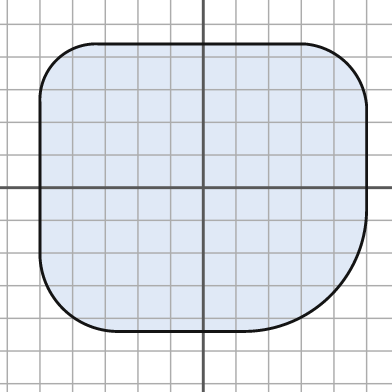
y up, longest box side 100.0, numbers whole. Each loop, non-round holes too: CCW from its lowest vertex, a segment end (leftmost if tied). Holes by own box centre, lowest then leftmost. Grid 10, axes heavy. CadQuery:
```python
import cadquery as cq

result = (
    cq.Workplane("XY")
    .moveTo(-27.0, -44.0)
    .lineTo(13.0, -44.0)
    .threePointArc((39.0, -33.0), (50.0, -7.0))
    .lineTo(50.0, 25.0)
    .threePointArc((44.0, 38.0), (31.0, 44.0))
    .lineTo(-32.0, 44.0)
    .threePointArc((-45.0, 39.0), (-50.0, 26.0))
    .lineTo(-50.0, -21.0)
    .threePointArc((-43.0, -37.0), (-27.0, -44.0))
    .close()
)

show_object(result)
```